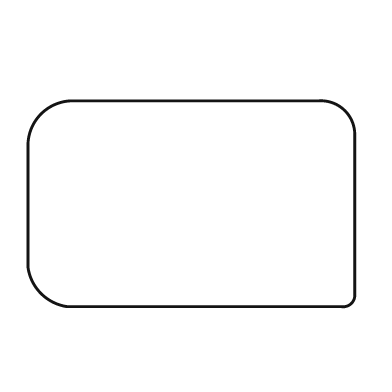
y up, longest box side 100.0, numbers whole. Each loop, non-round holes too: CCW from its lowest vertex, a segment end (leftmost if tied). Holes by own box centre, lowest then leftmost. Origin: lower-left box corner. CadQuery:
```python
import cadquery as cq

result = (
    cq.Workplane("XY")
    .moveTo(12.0, 0.0)
    .lineTo(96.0, 0.0)
    .threePointArc((99.0, 1.0), (100.0, 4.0))
    .lineTo(100.0, 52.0)
    .threePointArc((97.0, 60.0), (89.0, 63.0))
    .lineTo(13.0, 63.0)
    .threePointArc((4.0, 59.0), (0.0, 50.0))
    .lineTo(0.0, 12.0)
    .threePointArc((4.0, 4.0), (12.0, 0.0))
    .close()
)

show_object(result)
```